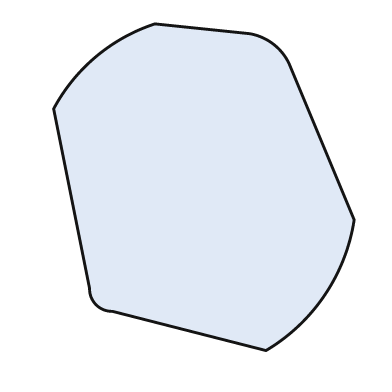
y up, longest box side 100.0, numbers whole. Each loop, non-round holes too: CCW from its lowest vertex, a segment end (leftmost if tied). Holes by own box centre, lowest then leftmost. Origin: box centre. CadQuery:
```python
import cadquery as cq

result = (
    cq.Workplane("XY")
    .moveTo(19.0, -50.0)
    .threePointArc((37.0, -33.0), (46.0, -10.0))
    .lineTo(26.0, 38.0)
    .threePointArc((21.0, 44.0), (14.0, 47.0))
    .lineTo(-15.0, 50.0)
    .threePointArc((-33.0, 40.0), (-46.0, 24.0))
    .lineTo(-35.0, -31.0)
    .threePointArc((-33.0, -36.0), (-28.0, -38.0))
    .close()
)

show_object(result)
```